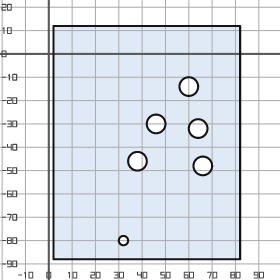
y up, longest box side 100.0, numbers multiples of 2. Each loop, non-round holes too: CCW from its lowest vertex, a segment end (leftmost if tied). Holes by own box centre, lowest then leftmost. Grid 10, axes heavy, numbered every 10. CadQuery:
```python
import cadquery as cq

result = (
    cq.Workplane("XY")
    .moveTo(2.0, -88.0)
    .lineTo(82.0, -88.0)
    .lineTo(82.0, 12.0)
    .lineTo(2.0, 12.0)
    .close()
    .moveTo(32.0, -80.0)
    .circle(2.0)
    .moveTo(66.0, -48.0)
    .circle(4.0)
    .moveTo(38.0, -46.0)
    .circle(4.0)
    .moveTo(64.0, -32.0)
    .circle(4.0)
    .moveTo(46.0, -30.0)
    .circle(4.0)
    .moveTo(60.0, -14.0)
    .circle(4.0)
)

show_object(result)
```